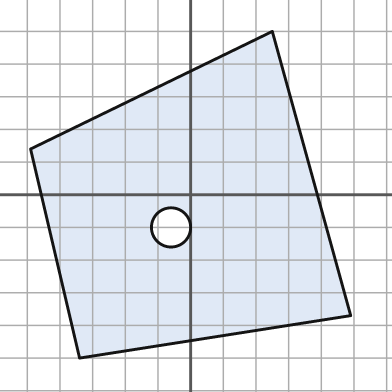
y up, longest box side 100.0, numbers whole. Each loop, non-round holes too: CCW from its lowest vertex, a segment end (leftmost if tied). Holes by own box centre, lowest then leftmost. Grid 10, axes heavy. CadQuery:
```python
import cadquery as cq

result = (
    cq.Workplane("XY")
    .moveTo(-34.0, -50.0)
    .lineTo(49.0, -37.0)
    .lineTo(25.0, 50.0)
    .lineTo(-49.0, 14.0)
    .close()
    .moveTo(-6.0, -10.0)
    .circle(6.0)
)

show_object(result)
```